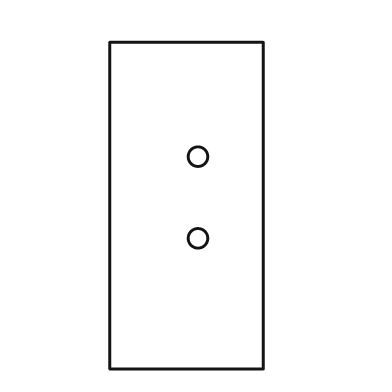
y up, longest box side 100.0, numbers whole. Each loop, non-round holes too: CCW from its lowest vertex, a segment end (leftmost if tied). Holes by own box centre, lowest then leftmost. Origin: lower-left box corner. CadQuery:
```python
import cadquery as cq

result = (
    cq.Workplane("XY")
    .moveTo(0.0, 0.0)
    .lineTo(47.0, 0.0)
    .lineTo(47.0, 100.0)
    .lineTo(0.0, 100.0)
    .close()
    .moveTo(27.0, 40.0)
    .circle(3.0)
    .moveTo(27.0, 65.0)
    .circle(3.0)
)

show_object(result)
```